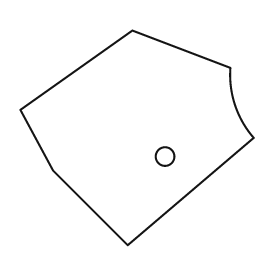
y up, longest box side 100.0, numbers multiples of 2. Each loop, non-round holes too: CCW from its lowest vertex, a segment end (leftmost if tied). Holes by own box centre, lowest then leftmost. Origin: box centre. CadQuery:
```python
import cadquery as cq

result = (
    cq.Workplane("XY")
    .moveTo(-4.0, -46.0)
    .lineTo(50.0, 0.0)
    .threePointArc((42.0, 14.0), (40.0, 30.0))
    .lineTo(-2.0, 46.0)
    .lineTo(-50.0, 12.0)
    .lineTo(-36.0, -14.0)
    .close()
    .moveTo(12.0, -8.0)
    .circle(4.0)
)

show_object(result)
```